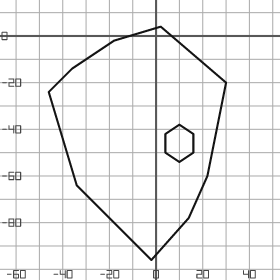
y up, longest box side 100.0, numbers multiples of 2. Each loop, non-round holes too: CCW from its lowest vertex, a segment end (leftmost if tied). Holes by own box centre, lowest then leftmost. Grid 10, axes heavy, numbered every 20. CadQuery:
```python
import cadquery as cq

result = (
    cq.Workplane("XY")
    .moveTo(-2.0, -96.0)
    .lineTo(14.0, -78.0)
    .lineTo(22.0, -60.0)
    .lineTo(30.0, -20.0)
    .lineTo(2.0, 4.0)
    .lineTo(-18.0, -2.0)
    .lineTo(-36.0, -14.0)
    .lineTo(-46.0, -24.0)
    .lineTo(-34.0, -64.0)
    .close()
    .moveTo(10.0, -54.0)
    .lineTo(16.0, -50.0)
    .lineTo(16.0, -42.0)
    .lineTo(10.0, -38.0)
    .lineTo(4.0, -42.0)
    .lineTo(4.0, -50.0)
    .close()
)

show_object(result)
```